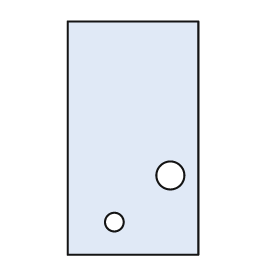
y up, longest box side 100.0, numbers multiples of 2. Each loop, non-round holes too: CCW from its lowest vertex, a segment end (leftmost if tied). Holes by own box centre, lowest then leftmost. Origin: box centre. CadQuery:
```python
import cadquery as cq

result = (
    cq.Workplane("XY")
    .moveTo(-28.0, -50.0)
    .lineTo(28.0, -50.0)
    .lineTo(28.0, 50.0)
    .lineTo(-28.0, 50.0)
    .close()
    .moveTo(-8.0, -36.0)
    .circle(4.0)
    .moveTo(16.0, -16.0)
    .circle(6.0)
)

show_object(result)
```